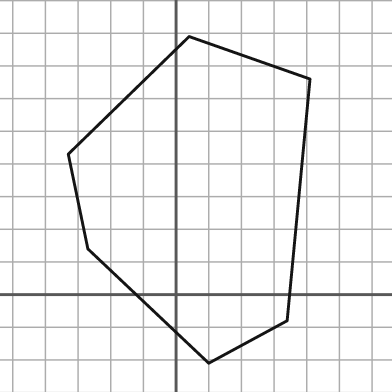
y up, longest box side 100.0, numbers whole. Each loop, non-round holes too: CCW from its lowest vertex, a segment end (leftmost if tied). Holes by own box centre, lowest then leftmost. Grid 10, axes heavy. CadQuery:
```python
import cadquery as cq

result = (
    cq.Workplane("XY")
    .moveTo(10.0, -21.0)
    .lineTo(34.0, -8.0)
    .lineTo(41.0, 66.0)
    .lineTo(4.0, 79.0)
    .lineTo(-33.0, 43.0)
    .lineTo(-27.0, 14.0)
    .close()
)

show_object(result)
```